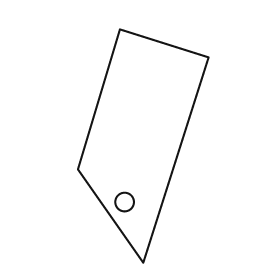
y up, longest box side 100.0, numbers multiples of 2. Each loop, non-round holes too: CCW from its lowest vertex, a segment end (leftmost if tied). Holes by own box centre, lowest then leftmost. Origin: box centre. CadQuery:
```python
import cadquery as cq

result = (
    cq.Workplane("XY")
    .moveTo(0.0, -50.0)
    .lineTo(28.0, 38.0)
    .lineTo(-10.0, 50.0)
    .lineTo(-28.0, -10.0)
    .close()
    .moveTo(-8.0, -24.0)
    .circle(4.0)
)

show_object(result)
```